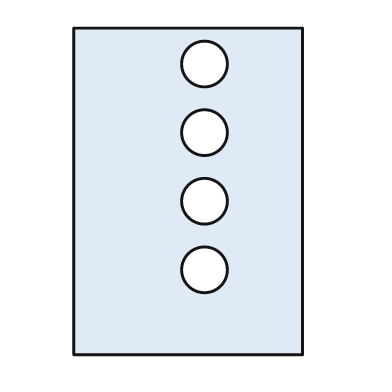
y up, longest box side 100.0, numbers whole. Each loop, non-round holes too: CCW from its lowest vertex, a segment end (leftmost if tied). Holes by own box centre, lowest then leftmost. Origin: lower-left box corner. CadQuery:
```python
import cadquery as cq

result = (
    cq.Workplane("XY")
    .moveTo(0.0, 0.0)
    .lineTo(70.0, 0.0)
    .lineTo(70.0, 100.0)
    .lineTo(0.0, 100.0)
    .close()
    .moveTo(40.0, 26.0)
    .circle(7.0)
    .moveTo(40.0, 47.0)
    .circle(7.0)
    .moveTo(40.0, 68.0)
    .circle(7.0)
    .moveTo(40.0, 89.0)
    .circle(7.0)
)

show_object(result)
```